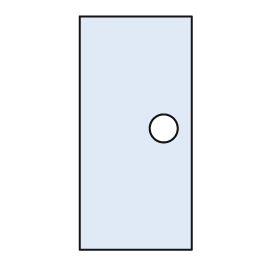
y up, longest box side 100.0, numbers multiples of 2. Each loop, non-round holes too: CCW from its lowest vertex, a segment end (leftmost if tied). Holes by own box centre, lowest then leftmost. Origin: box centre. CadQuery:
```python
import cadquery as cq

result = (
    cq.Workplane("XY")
    .moveTo(-24.0, -50.0)
    .lineTo(24.0, -50.0)
    .lineTo(24.0, 50.0)
    .lineTo(-24.0, 50.0)
    .close()
    .moveTo(12.0, 2.0)
    .circle(6.0)
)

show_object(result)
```